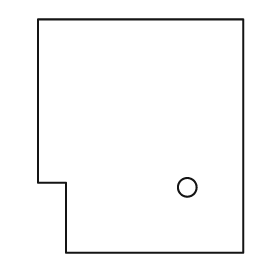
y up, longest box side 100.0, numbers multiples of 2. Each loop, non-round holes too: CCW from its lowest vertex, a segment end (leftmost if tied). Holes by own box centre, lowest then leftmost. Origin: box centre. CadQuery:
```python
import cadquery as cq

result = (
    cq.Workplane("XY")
    .moveTo(-32.0, -50.0)
    .lineTo(44.0, -50.0)
    .lineTo(44.0, 50.0)
    .lineTo(-44.0, 50.0)
    .lineTo(-44.0, -20.0)
    .lineTo(-32.0, -20.0)
    .close()
    .moveTo(20.0, -22.0)
    .circle(4.0)
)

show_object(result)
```